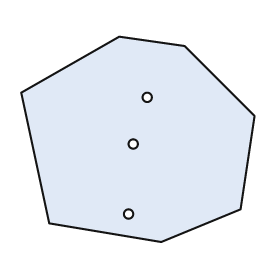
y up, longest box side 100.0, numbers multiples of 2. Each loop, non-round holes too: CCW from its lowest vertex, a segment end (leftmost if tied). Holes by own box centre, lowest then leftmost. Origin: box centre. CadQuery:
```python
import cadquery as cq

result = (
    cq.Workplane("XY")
    .moveTo(10.0, -44.0)
    .lineTo(44.0, -30.0)
    .lineTo(50.0, 10.0)
    .lineTo(20.0, 40.0)
    .lineTo(-8.0, 44.0)
    .lineTo(-50.0, 20.0)
    .lineTo(-38.0, -36.0)
    .close()
    .moveTo(-4.0, -32.0)
    .circle(2.0)
    .moveTo(-2.0, -2.0)
    .circle(2.0)
    .moveTo(4.0, 18.0)
    .circle(2.0)
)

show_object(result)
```